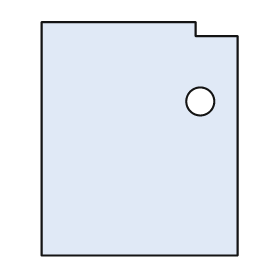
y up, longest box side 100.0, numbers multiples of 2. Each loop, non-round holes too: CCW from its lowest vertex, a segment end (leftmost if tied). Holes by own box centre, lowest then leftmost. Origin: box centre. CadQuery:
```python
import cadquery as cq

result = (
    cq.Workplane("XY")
    .moveTo(-42.0, -50.0)
    .lineTo(42.0, -50.0)
    .lineTo(42.0, 44.0)
    .lineTo(24.0, 44.0)
    .lineTo(24.0, 50.0)
    .lineTo(-42.0, 50.0)
    .close()
    .moveTo(26.0, 16.0)
    .circle(6.0)
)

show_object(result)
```